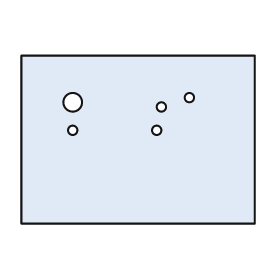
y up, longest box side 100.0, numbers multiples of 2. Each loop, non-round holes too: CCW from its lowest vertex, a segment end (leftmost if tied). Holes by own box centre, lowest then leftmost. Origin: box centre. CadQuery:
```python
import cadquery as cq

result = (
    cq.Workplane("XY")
    .moveTo(-50.0, -36.0)
    .lineTo(50.0, -36.0)
    .lineTo(50.0, 36.0)
    .lineTo(-50.0, 36.0)
    .close()
    .moveTo(-28.0, 4.0)
    .circle(2.0)
    .moveTo(8.0, 4.0)
    .circle(2.0)
    .moveTo(10.0, 14.0)
    .circle(2.0)
    .moveTo(-28.0, 16.0)
    .circle(4.0)
    .moveTo(22.0, 18.0)
    .circle(2.0)
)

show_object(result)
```